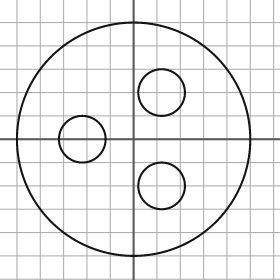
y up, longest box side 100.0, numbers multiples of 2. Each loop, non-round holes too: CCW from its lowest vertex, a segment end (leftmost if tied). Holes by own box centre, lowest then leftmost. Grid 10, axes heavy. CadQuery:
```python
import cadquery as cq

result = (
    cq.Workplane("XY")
    .moveTo(0.0, 0.0)
    .circle(50.0)
    .moveTo(12.0, -20.0)
    .circle(10.0)
    .moveTo(-22.0, 0.0)
    .circle(10.0)
    .moveTo(12.0, 20.0)
    .circle(10.0)
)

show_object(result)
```